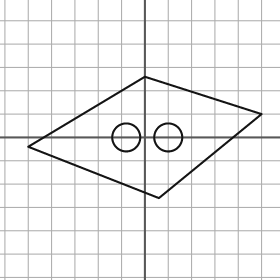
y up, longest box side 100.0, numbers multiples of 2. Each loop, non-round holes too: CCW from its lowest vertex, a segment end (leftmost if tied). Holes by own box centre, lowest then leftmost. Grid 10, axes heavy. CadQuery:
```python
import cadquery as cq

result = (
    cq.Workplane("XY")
    .moveTo(6.0, -26.0)
    .lineTo(50.0, 10.0)
    .lineTo(0.0, 26.0)
    .lineTo(-50.0, -4.0)
    .close()
    .moveTo(-8.0, 0.0)
    .circle(6.0)
    .moveTo(10.0, 0.0)
    .circle(6.0)
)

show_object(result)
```